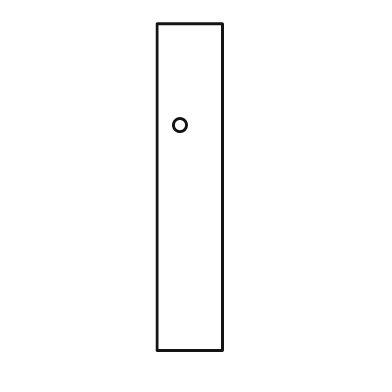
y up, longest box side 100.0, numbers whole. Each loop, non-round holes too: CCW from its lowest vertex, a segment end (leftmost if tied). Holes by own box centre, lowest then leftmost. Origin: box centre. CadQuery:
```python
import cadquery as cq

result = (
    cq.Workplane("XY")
    .moveTo(-10.0, -50.0)
    .lineTo(10.0, -50.0)
    .lineTo(10.0, 50.0)
    .lineTo(-10.0, 50.0)
    .close()
    .moveTo(-3.0, 19.0)
    .circle(2.0)
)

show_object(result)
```